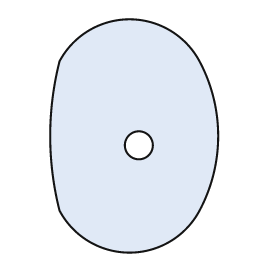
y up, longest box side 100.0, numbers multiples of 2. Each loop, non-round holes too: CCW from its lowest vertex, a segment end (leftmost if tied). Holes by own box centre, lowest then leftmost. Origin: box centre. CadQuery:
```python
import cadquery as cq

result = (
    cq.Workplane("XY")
    .moveTo(-32.0, -32.0)
    .threePointArc((-2.0, -50.0), (28.0, -32.0))
    .threePointArc((36.0, 0.0), (28.0, 32.0))
    .threePointArc((-2.0, 50.0), (-32.0, 32.0))
    .threePointArc((-36.0, 0.0), (-32.0, -32.0))
    .close()
    .moveTo(2.0, -4.0)
    .circle(6.0)
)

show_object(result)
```